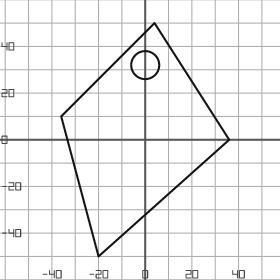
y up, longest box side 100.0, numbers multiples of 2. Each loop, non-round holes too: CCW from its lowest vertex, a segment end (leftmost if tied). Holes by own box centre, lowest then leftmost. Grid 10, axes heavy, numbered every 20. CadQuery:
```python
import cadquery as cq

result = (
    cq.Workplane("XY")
    .moveTo(-20.0, -50.0)
    .lineTo(36.0, 0.0)
    .lineTo(4.0, 50.0)
    .lineTo(-36.0, 10.0)
    .close()
    .moveTo(0.0, 32.0)
    .circle(6.0)
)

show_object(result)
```